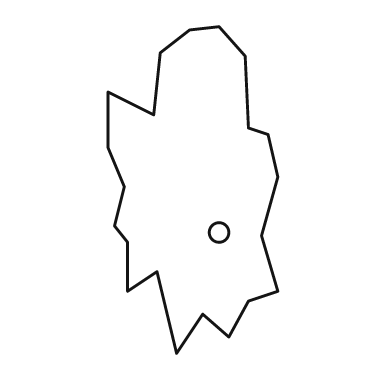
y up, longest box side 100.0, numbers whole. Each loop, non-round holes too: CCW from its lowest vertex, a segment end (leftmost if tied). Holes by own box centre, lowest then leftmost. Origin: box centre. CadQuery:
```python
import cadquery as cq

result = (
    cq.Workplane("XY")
    .moveTo(-5.0, -50.0)
    .lineTo(3.0, -38.0)
    .lineTo(11.0, -45.0)
    .lineTo(17.0, -34.0)
    .lineTo(26.0, -31.0)
    .lineTo(21.0, -14.0)
    .lineTo(26.0, 4.0)
    .lineTo(23.0, 17.0)
    .lineTo(17.0, 19.0)
    .lineTo(16.0, 41.0)
    .lineTo(8.0, 50.0)
    .lineTo(-1.0, 49.0)
    .lineTo(-10.0, 42.0)
    .lineTo(-12.0, 23.0)
    .lineTo(-26.0, 30.0)
    .lineTo(-26.0, 13.0)
    .lineTo(-21.0, 1.0)
    .lineTo(-24.0, -11.0)
    .lineTo(-20.0, -16.0)
    .lineTo(-20.0, -31.0)
    .lineTo(-11.0, -25.0)
    .close()
    .moveTo(8.0, -13.0)
    .circle(3.0)
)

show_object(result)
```